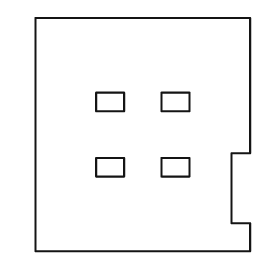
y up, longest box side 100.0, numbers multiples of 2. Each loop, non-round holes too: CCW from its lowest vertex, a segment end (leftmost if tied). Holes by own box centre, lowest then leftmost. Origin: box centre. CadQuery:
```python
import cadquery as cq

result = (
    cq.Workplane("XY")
    .moveTo(-46.0, -50.0)
    .lineTo(46.0, -50.0)
    .lineTo(46.0, -38.0)
    .lineTo(38.0, -38.0)
    .lineTo(38.0, -8.0)
    .lineTo(46.0, -8.0)
    .lineTo(46.0, 50.0)
    .lineTo(-46.0, 50.0)
    .close()
    .moveTo(-20.0, -18.0)
    .lineTo(-8.0, -18.0)
    .lineTo(-8.0, -10.0)
    .lineTo(-20.0, -10.0)
    .close()
    .moveTo(8.0, -18.0)
    .lineTo(20.0, -18.0)
    .lineTo(20.0, -10.0)
    .lineTo(8.0, -10.0)
    .close()
    .moveTo(-20.0, 10.0)
    .lineTo(-8.0, 10.0)
    .lineTo(-8.0, 18.0)
    .lineTo(-20.0, 18.0)
    .close()
    .moveTo(8.0, 10.0)
    .lineTo(20.0, 10.0)
    .lineTo(20.0, 18.0)
    .lineTo(8.0, 18.0)
    .close()
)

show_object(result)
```